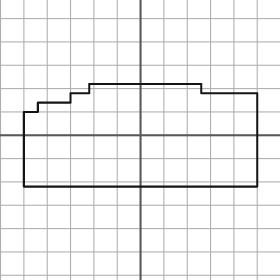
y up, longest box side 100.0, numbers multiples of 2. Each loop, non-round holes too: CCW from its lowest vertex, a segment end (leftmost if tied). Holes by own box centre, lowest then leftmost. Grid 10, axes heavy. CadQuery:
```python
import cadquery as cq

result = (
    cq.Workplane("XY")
    .moveTo(-50.0, -22.0)
    .lineTo(50.0, -22.0)
    .lineTo(50.0, 18.0)
    .lineTo(26.0, 18.0)
    .lineTo(26.0, 22.0)
    .lineTo(-22.0, 22.0)
    .lineTo(-22.0, 18.0)
    .lineTo(-30.0, 18.0)
    .lineTo(-30.0, 14.0)
    .lineTo(-44.0, 14.0)
    .lineTo(-44.0, 10.0)
    .lineTo(-50.0, 10.0)
    .close()
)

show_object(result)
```